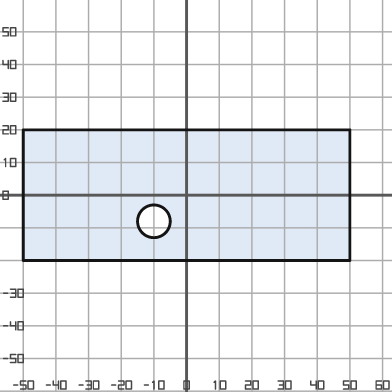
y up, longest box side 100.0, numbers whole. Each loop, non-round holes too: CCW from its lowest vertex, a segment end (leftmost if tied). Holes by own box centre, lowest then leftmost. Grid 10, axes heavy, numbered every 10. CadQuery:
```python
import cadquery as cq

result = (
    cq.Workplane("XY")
    .moveTo(-50.0, -20.0)
    .lineTo(50.0, -20.0)
    .lineTo(50.0, 20.0)
    .lineTo(-50.0, 20.0)
    .close()
    .moveTo(-10.0, -8.0)
    .circle(5.0)
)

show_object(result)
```